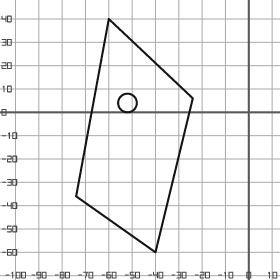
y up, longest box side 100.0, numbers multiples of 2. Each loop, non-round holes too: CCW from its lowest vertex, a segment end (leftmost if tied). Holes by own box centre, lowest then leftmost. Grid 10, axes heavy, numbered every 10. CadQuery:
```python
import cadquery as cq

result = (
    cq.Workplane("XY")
    .moveTo(-40.0, -60.0)
    .lineTo(-24.0, 6.0)
    .lineTo(-60.0, 40.0)
    .lineTo(-74.0, -36.0)
    .close()
    .moveTo(-52.0, 4.0)
    .circle(4.0)
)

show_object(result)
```